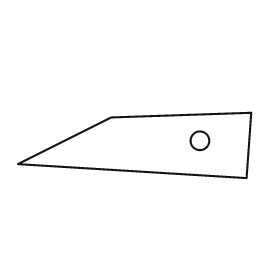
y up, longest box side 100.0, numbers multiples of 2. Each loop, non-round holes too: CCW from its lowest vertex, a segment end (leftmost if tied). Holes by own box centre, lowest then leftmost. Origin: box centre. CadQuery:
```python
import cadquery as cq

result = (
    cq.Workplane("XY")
    .moveTo(48.0, -14.0)
    .lineTo(50.0, 14.0)
    .lineTo(-10.0, 12.0)
    .lineTo(-50.0, -8.0)
    .close()
    .moveTo(28.0, 2.0)
    .circle(4.0)
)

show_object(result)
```